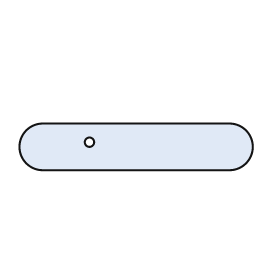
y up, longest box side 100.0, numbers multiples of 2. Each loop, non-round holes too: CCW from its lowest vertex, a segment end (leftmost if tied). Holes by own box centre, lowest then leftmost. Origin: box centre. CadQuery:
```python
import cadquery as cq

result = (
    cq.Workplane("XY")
    .moveTo(-40.0, -10.0)
    .lineTo(40.0, -10.0)
    .threePointArc((50.0, 0.0), (40.0, 10.0))
    .lineTo(-40.0, 10.0)
    .threePointArc((-50.0, 0.0), (-40.0, -10.0))
    .close()
    .moveTo(-20.0, 2.0)
    .circle(2.0)
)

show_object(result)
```